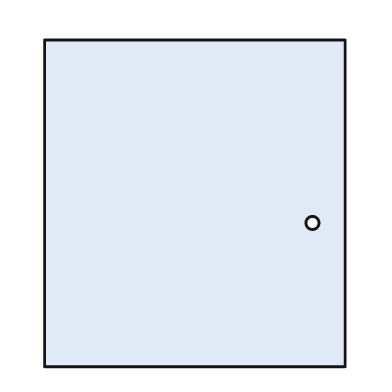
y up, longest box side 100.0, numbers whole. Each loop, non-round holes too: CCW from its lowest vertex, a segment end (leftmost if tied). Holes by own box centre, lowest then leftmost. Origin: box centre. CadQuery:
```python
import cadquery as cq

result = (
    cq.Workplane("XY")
    .moveTo(-46.0, -50.0)
    .lineTo(46.0, -50.0)
    .lineTo(46.0, 50.0)
    .lineTo(-46.0, 50.0)
    .close()
    .moveTo(36.0, -6.0)
    .circle(2.0)
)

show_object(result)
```